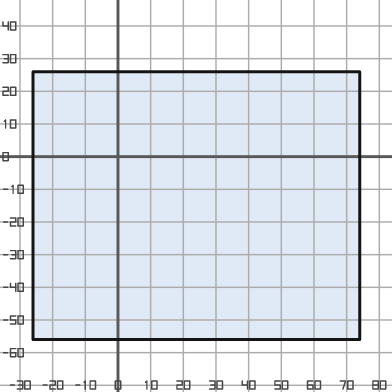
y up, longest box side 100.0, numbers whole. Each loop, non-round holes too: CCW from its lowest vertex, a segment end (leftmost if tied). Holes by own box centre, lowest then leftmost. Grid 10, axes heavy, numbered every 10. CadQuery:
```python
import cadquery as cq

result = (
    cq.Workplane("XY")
    .moveTo(-26.0, -56.0)
    .lineTo(74.0, -56.0)
    .lineTo(74.0, 26.0)
    .lineTo(-26.0, 26.0)
    .close()
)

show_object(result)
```